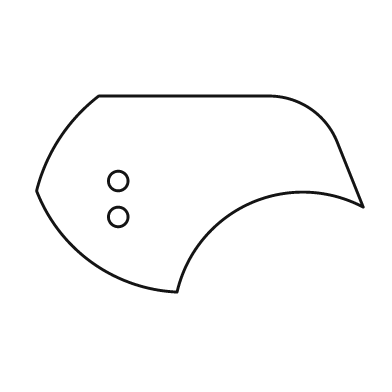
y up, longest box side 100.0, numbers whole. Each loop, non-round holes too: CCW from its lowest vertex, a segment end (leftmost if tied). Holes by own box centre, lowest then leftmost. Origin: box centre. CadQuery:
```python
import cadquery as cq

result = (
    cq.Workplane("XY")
    .moveTo(-7.0, -30.0)
    .threePointArc((15.0, -3.0), (50.0, -4.0))
    .lineTo(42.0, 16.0)
    .threePointArc((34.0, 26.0), (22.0, 30.0))
    .lineTo(-31.0, 30.0)
    .threePointArc((-43.0, 17.0), (-50.0, 1.0))
    .threePointArc((-33.0, -21.0), (-7.0, -30.0))
    .close()
    .moveTo(-25.0, -7.0)
    .circle(3.0)
    .moveTo(-25.0, 4.0)
    .circle(3.0)
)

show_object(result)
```